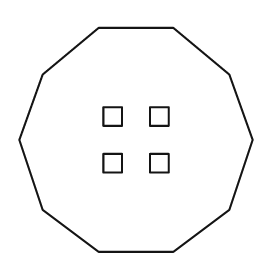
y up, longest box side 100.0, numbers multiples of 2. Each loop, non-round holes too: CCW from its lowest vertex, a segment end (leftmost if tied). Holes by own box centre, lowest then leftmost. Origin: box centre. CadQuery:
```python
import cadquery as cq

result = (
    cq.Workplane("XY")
    .moveTo(-16.0, -48.0)
    .lineTo(16.0, -48.0)
    .lineTo(40.0, -30.0)
    .lineTo(50.0, 0.0)
    .lineTo(40.0, 28.0)
    .lineTo(16.0, 48.0)
    .lineTo(-16.0, 48.0)
    .lineTo(-40.0, 28.0)
    .lineTo(-50.0, 0.0)
    .lineTo(-40.0, -30.0)
    .close()
    .moveTo(-14.0, -14.0)
    .lineTo(-6.0, -14.0)
    .lineTo(-6.0, -6.0)
    .lineTo(-14.0, -6.0)
    .close()
    .moveTo(6.0, -14.0)
    .lineTo(14.0, -14.0)
    .lineTo(14.0, -6.0)
    .lineTo(6.0, -6.0)
    .close()
    .moveTo(-14.0, 6.0)
    .lineTo(-6.0, 6.0)
    .lineTo(-6.0, 14.0)
    .lineTo(-14.0, 14.0)
    .close()
    .moveTo(6.0, 6.0)
    .lineTo(14.0, 6.0)
    .lineTo(14.0, 14.0)
    .lineTo(6.0, 14.0)
    .close()
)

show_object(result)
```